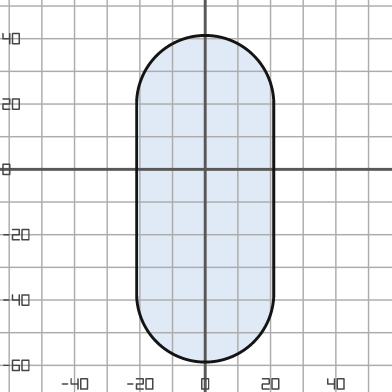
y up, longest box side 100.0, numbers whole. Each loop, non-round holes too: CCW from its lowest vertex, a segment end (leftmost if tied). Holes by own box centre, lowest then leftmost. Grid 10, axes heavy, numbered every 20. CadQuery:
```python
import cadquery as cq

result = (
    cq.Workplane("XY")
    .moveTo(-21.0, -38.0)
    .threePointArc((0.0, -59.0), (21.0, -38.0))
    .lineTo(21.0, 20.0)
    .threePointArc((0.0, 41.0), (-21.0, 20.0))
    .close()
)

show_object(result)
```